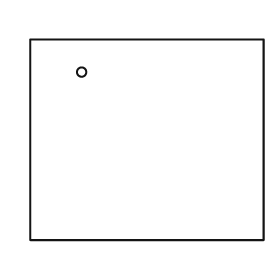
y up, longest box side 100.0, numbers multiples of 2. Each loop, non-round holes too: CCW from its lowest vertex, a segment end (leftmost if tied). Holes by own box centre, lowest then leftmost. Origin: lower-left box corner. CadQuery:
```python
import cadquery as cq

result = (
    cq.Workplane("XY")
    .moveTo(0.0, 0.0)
    .lineTo(100.0, 0.0)
    .lineTo(100.0, 86.0)
    .lineTo(0.0, 86.0)
    .close()
    .moveTo(22.0, 72.0)
    .circle(2.0)
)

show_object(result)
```